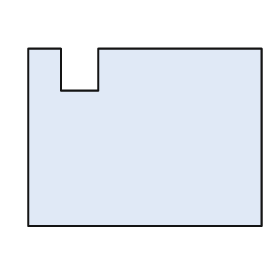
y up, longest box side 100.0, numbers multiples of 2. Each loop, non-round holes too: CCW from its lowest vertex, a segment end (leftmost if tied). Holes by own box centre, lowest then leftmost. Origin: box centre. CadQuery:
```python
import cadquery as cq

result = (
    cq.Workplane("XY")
    .moveTo(-50.0, -38.0)
    .lineTo(50.0, -38.0)
    .lineTo(50.0, 38.0)
    .lineTo(-20.0, 38.0)
    .lineTo(-20.0, 20.0)
    .lineTo(-36.0, 20.0)
    .lineTo(-36.0, 38.0)
    .lineTo(-50.0, 38.0)
    .close()
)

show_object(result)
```